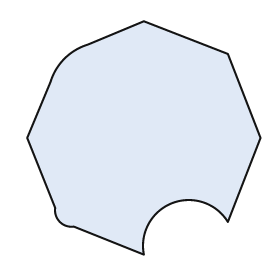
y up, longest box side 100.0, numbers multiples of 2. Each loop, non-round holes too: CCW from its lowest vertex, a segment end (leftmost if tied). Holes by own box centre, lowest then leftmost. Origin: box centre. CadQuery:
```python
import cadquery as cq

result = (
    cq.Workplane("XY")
    .moveTo(0.0, -50.0)
    .threePointArc((12.0, -28.0), (36.0, -36.0))
    .lineTo(50.0, 0.0)
    .lineTo(36.0, 36.0)
    .lineTo(0.0, 50.0)
    .lineTo(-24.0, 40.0)
    .threePointArc((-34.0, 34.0), (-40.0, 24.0))
    .lineTo(-50.0, 0.0)
    .lineTo(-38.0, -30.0)
    .threePointArc((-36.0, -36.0), (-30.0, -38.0))
    .close()
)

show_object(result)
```